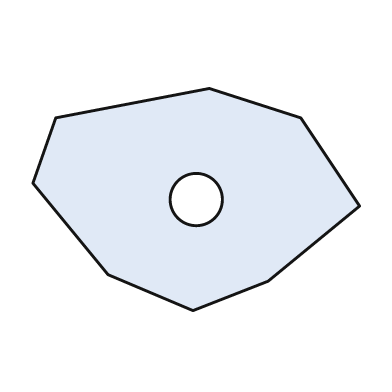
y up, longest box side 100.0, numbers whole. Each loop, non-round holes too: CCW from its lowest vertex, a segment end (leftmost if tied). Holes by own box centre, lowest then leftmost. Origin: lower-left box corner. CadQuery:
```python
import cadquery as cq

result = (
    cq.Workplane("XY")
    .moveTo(49.0, 0.0)
    .lineTo(72.0, 9.0)
    .lineTo(100.0, 32.0)
    .lineTo(82.0, 59.0)
    .lineTo(54.0, 68.0)
    .lineTo(7.0, 59.0)
    .lineTo(0.0, 39.0)
    .lineTo(23.0, 11.0)
    .close()
    .moveTo(50.0, 34.0)
    .circle(8.0)
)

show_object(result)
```